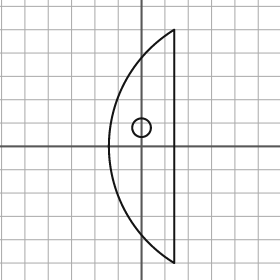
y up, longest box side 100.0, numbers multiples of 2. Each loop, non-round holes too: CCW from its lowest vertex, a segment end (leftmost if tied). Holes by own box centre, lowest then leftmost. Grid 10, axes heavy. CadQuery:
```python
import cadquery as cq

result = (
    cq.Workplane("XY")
    .moveTo(14.0, -50.0)
    .lineTo(14.0, 50.0)
    .threePointArc((-14.0, 0.0), (14.0, -50.0))
    .close()
    .moveTo(0.0, 8.0)
    .circle(4.0)
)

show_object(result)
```